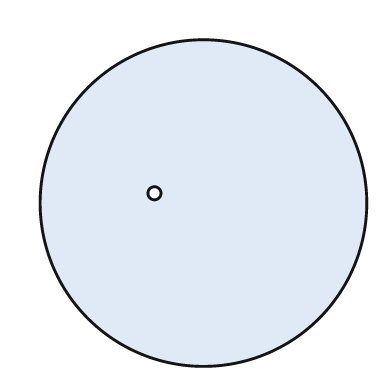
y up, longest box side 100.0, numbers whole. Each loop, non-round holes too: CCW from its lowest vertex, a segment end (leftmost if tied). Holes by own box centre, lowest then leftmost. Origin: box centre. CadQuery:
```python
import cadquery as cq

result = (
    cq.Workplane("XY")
    .moveTo(0.0, 0.0)
    .circle(50.0)
    .moveTo(-15.0, 3.0)
    .circle(2.0)
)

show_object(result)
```